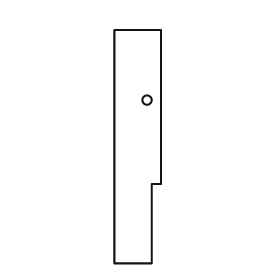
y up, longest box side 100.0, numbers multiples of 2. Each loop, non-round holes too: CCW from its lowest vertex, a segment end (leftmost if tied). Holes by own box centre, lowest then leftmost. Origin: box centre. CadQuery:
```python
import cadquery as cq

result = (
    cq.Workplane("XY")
    .moveTo(-10.0, -50.0)
    .lineTo(6.0, -50.0)
    .lineTo(6.0, -16.0)
    .lineTo(10.0, -16.0)
    .lineTo(10.0, 50.0)
    .lineTo(-10.0, 50.0)
    .close()
    .moveTo(4.0, 20.0)
    .circle(2.0)
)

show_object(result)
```